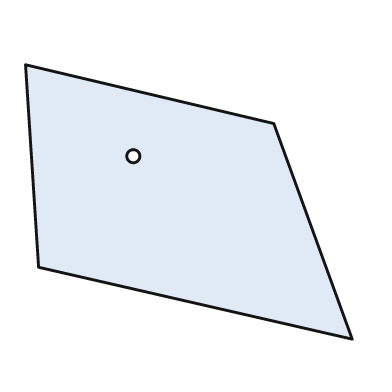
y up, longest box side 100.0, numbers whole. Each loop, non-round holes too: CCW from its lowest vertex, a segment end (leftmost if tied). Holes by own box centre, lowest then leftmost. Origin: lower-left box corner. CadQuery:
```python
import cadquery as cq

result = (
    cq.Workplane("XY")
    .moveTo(100.0, 0.0)
    .lineTo(76.0, 66.0)
    .lineTo(0.0, 84.0)
    .lineTo(4.0, 22.0)
    .close()
    .moveTo(33.0, 56.0)
    .circle(2.0)
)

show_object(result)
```